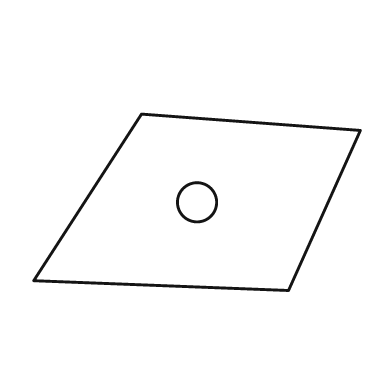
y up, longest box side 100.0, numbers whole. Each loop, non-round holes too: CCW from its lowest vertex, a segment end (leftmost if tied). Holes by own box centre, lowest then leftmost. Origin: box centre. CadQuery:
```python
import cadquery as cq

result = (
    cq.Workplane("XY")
    .moveTo(28.0, -27.0)
    .lineTo(50.0, 22.0)
    .lineTo(-17.0, 27.0)
    .lineTo(-50.0, -24.0)
    .close()
    .moveTo(0.0, 0.0)
    .circle(6.0)
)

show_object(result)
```